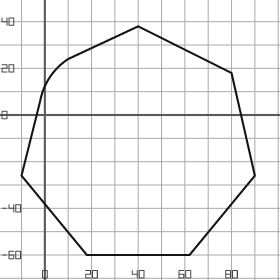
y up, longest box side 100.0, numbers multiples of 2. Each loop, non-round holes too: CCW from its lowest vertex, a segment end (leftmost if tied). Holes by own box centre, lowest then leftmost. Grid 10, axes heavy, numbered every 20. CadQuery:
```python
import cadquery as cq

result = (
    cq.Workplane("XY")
    .moveTo(18.0, -60.0)
    .lineTo(62.0, -60.0)
    .lineTo(90.0, -26.0)
    .lineTo(80.0, 18.0)
    .lineTo(40.0, 38.0)
    .lineTo(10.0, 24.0)
    .threePointArc((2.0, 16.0), (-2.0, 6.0))
    .lineTo(-10.0, -26.0)
    .close()
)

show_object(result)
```